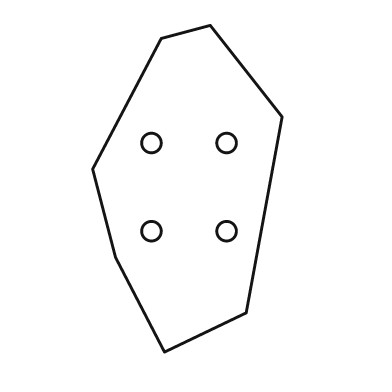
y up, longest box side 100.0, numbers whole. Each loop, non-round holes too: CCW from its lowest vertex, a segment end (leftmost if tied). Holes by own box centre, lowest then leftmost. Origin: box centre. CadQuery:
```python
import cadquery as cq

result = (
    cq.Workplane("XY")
    .moveTo(-7.0, -50.0)
    .lineTo(18.0, -38.0)
    .lineTo(29.0, 22.0)
    .lineTo(7.0, 50.0)
    .lineTo(-8.0, 46.0)
    .lineTo(-29.0, 6.0)
    .lineTo(-22.0, -21.0)
    .close()
    .moveTo(-11.0, -13.0)
    .circle(3.0)
    .moveTo(12.0, -13.0)
    .circle(3.0)
    .moveTo(-11.0, 14.0)
    .circle(3.0)
    .moveTo(12.0, 14.0)
    .circle(3.0)
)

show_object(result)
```